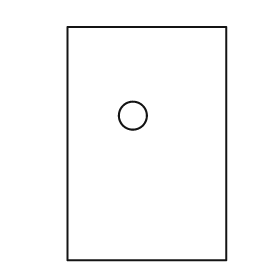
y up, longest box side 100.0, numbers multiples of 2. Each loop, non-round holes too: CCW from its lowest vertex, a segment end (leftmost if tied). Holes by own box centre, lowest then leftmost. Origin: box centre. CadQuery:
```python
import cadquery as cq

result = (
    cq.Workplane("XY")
    .moveTo(-34.0, -50.0)
    .lineTo(34.0, -50.0)
    .lineTo(34.0, 50.0)
    .lineTo(-34.0, 50.0)
    .close()
    .moveTo(-6.0, 12.0)
    .circle(6.0)
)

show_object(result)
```